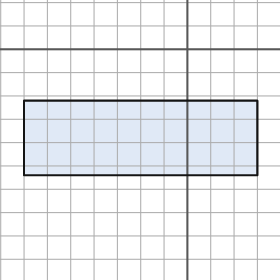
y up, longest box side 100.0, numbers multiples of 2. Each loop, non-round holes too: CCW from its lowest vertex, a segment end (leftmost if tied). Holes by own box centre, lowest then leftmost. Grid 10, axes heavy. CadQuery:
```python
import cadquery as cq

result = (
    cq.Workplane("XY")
    .moveTo(-70.0, -54.0)
    .lineTo(30.0, -54.0)
    .lineTo(30.0, -22.0)
    .lineTo(-70.0, -22.0)
    .close()
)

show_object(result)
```